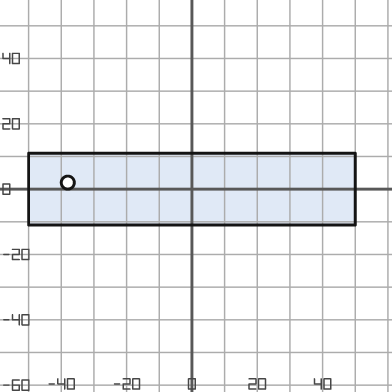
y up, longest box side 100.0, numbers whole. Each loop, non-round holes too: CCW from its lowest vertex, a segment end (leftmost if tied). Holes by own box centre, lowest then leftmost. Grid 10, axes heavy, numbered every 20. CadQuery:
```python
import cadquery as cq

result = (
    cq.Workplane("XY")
    .moveTo(-50.0, -11.0)
    .lineTo(50.0, -11.0)
    .lineTo(50.0, 11.0)
    .lineTo(-50.0, 11.0)
    .close()
    .moveTo(-38.0, 2.0)
    .circle(2.0)
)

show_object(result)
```